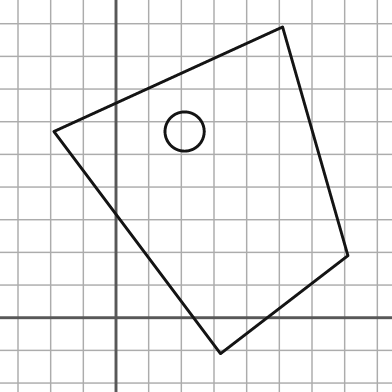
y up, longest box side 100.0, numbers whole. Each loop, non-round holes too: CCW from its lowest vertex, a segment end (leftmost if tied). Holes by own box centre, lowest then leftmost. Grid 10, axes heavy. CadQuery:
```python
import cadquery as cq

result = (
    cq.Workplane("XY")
    .moveTo(32.0, -11.0)
    .lineTo(71.0, 19.0)
    .lineTo(51.0, 89.0)
    .lineTo(-19.0, 57.0)
    .close()
    .moveTo(21.0, 57.0)
    .circle(6.0)
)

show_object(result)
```